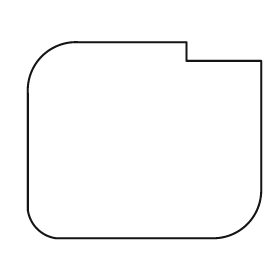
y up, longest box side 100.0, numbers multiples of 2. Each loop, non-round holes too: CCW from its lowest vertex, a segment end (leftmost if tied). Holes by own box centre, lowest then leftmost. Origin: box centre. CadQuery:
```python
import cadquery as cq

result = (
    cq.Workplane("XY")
    .moveTo(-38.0, -42.0)
    .lineTo(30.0, -42.0)
    .threePointArc((44.0, -36.0), (50.0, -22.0))
    .lineTo(50.0, 34.0)
    .lineTo(18.0, 34.0)
    .lineTo(18.0, 42.0)
    .lineTo(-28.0, 42.0)
    .threePointArc((-44.0, 36.0), (-50.0, 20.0))
    .lineTo(-50.0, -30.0)
    .threePointArc((-46.0, -38.0), (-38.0, -42.0))
    .close()
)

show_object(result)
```